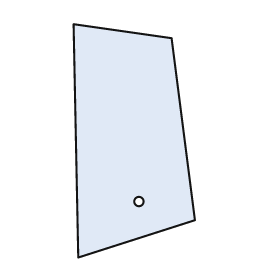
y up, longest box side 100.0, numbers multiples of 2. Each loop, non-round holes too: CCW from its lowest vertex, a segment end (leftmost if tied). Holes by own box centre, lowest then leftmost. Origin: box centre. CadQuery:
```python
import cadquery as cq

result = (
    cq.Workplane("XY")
    .moveTo(-24.0, -50.0)
    .lineTo(26.0, -34.0)
    .lineTo(16.0, 44.0)
    .lineTo(-26.0, 50.0)
    .close()
    .moveTo(2.0, -26.0)
    .circle(2.0)
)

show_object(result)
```